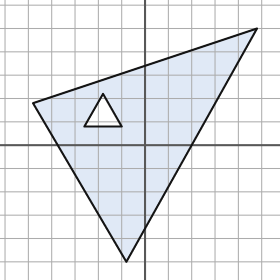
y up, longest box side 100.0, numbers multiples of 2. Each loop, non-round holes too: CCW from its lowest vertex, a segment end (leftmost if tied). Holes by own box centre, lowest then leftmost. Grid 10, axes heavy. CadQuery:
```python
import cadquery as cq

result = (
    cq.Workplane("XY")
    .moveTo(-8.0, -50.0)
    .lineTo(48.0, 50.0)
    .lineTo(-48.0, 18.0)
    .close()
    .moveTo(-26.0, 8.0)
    .lineTo(-10.0, 8.0)
    .lineTo(-18.0, 22.0)
    .close()
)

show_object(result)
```